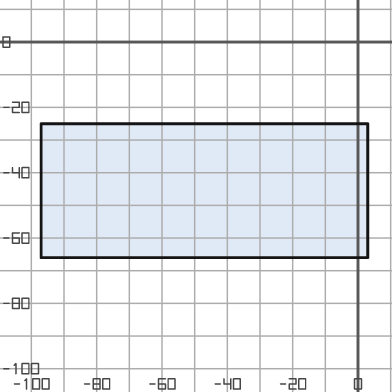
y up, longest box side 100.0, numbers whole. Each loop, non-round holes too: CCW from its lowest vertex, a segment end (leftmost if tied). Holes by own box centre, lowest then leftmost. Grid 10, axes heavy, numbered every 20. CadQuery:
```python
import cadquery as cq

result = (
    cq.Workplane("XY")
    .moveTo(-97.0, -66.0)
    .lineTo(3.0, -66.0)
    .lineTo(3.0, -25.0)
    .lineTo(-97.0, -25.0)
    .close()
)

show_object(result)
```